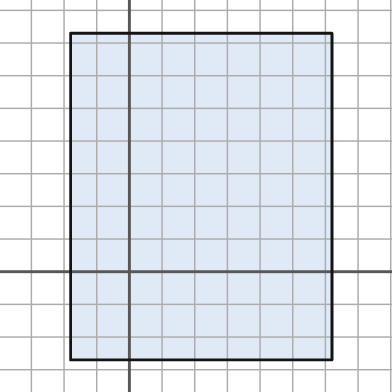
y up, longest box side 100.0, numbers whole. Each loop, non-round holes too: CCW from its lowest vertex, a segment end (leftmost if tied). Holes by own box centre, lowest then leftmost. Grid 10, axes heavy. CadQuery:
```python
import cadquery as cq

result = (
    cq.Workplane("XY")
    .moveTo(-18.0, -27.0)
    .lineTo(62.0, -27.0)
    .lineTo(62.0, 73.0)
    .lineTo(-18.0, 73.0)
    .close()
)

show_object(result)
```